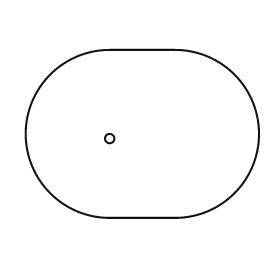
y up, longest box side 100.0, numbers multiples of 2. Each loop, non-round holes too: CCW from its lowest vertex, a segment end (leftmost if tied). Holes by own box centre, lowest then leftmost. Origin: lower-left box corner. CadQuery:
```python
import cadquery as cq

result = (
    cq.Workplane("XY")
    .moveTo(36.0, 0.0)
    .lineTo(64.0, 0.0)
    .threePointArc((100.0, 36.0), (64.0, 72.0))
    .lineTo(36.0, 72.0)
    .threePointArc((0.0, 36.0), (36.0, 0.0))
    .close()
    .moveTo(36.0, 34.0)
    .circle(2.0)
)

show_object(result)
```